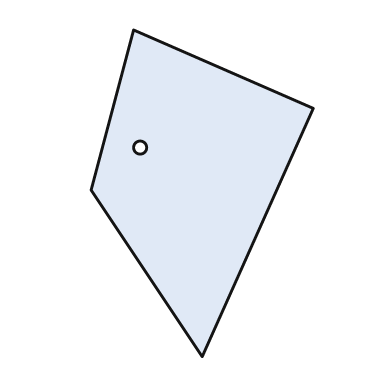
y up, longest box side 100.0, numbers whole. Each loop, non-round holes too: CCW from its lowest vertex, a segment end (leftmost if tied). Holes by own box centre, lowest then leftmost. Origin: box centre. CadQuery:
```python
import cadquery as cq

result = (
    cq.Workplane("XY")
    .moveTo(0.0, -50.0)
    .lineTo(34.0, 26.0)
    .lineTo(-21.0, 50.0)
    .lineTo(-34.0, 1.0)
    .close()
    .moveTo(-19.0, 14.0)
    .circle(2.0)
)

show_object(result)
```